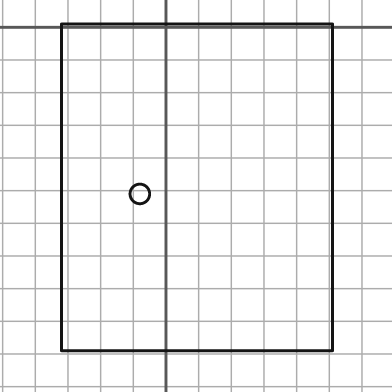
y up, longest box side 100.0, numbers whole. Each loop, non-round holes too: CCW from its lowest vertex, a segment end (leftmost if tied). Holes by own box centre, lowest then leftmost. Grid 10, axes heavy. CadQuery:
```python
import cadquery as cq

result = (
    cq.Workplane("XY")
    .moveTo(-32.0, -99.0)
    .lineTo(51.0, -99.0)
    .lineTo(51.0, 1.0)
    .lineTo(-32.0, 1.0)
    .close()
    .moveTo(-8.0, -51.0)
    .circle(3.0)
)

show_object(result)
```